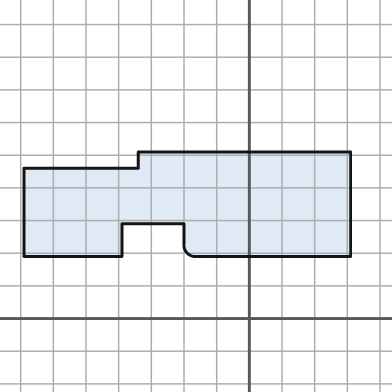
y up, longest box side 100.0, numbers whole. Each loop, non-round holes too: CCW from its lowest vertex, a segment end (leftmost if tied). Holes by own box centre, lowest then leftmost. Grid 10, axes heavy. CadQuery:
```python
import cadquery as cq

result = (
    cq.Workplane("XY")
    .moveTo(-69.0, 19.0)
    .lineTo(-39.0, 19.0)
    .lineTo(-39.0, 29.0)
    .lineTo(-20.0, 29.0)
    .lineTo(-20.0, 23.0)
    .threePointArc((-19.0, 20.0), (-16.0, 19.0))
    .lineTo(31.0, 19.0)
    .lineTo(31.0, 51.0)
    .lineTo(-34.0, 51.0)
    .lineTo(-34.0, 46.0)
    .lineTo(-69.0, 46.0)
    .close()
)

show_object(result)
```